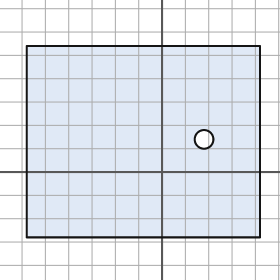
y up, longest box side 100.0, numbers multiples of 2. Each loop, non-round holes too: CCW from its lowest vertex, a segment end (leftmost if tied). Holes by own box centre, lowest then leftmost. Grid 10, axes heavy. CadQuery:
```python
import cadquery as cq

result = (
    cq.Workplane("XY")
    .moveTo(-58.0, -28.0)
    .lineTo(42.0, -28.0)
    .lineTo(42.0, 54.0)
    .lineTo(-58.0, 54.0)
    .close()
    .moveTo(18.0, 14.0)
    .circle(4.0)
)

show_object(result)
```